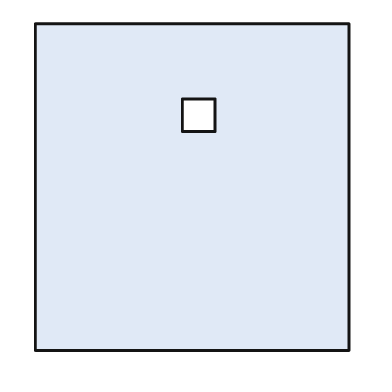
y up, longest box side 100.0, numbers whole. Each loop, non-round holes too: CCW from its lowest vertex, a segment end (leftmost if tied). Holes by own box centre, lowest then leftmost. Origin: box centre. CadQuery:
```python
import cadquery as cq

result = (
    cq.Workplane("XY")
    .moveTo(-48.0, -50.0)
    .lineTo(48.0, -50.0)
    .lineTo(48.0, 50.0)
    .lineTo(-48.0, 50.0)
    .close()
    .moveTo(-3.0, 17.0)
    .lineTo(7.0, 17.0)
    .lineTo(7.0, 27.0)
    .lineTo(-3.0, 27.0)
    .close()
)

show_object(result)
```